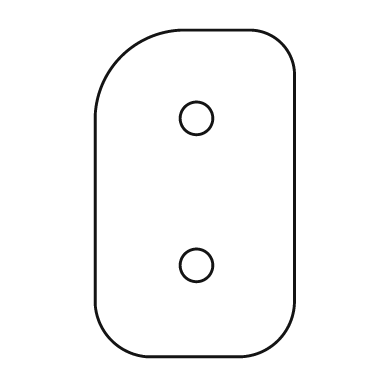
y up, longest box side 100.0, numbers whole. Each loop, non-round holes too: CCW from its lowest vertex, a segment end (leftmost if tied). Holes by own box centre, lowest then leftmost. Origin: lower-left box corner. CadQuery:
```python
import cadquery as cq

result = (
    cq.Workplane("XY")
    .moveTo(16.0, 0.0)
    .lineTo(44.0, 0.0)
    .threePointArc((56.0, 5.0), (61.0, 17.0))
    .lineTo(61.0, 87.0)
    .threePointArc((57.0, 96.0), (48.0, 100.0))
    .lineTo(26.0, 100.0)
    .threePointArc((8.0, 92.0), (0.0, 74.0))
    .lineTo(0.0, 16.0)
    .threePointArc((5.0, 5.0), (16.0, 0.0))
    .close()
    .moveTo(31.0, 28.0)
    .circle(5.0)
    .moveTo(31.0, 73.0)
    .circle(5.0)
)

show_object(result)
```